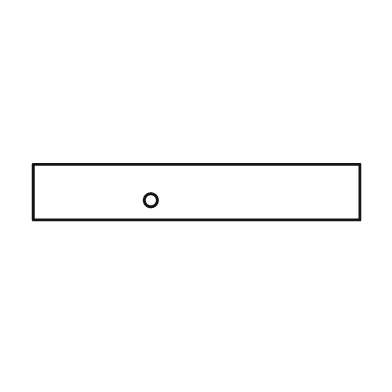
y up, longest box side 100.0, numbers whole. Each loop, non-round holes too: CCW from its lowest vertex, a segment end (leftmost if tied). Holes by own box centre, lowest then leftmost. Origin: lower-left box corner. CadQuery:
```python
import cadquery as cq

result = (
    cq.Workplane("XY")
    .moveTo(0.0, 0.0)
    .lineTo(100.0, 0.0)
    .lineTo(100.0, 17.0)
    .lineTo(0.0, 17.0)
    .close()
    .moveTo(36.0, 6.0)
    .circle(2.0)
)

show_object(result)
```